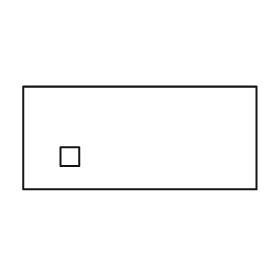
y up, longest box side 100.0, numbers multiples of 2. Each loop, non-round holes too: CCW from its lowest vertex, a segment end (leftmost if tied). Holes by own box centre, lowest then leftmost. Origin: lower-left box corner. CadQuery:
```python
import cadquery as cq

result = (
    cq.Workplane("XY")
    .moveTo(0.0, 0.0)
    .lineTo(100.0, 0.0)
    .lineTo(100.0, 44.0)
    .lineTo(0.0, 44.0)
    .close()
    .moveTo(16.0, 10.0)
    .lineTo(24.0, 10.0)
    .lineTo(24.0, 18.0)
    .lineTo(16.0, 18.0)
    .close()
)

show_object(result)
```